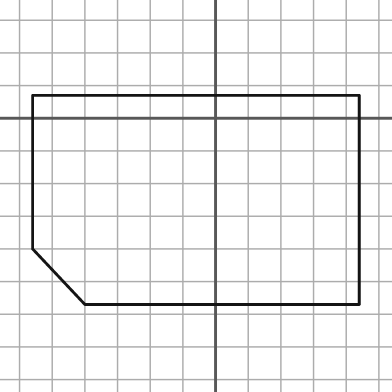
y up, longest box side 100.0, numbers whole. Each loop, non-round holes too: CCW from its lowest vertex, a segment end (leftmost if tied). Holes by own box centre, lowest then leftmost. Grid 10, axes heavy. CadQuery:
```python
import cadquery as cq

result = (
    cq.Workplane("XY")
    .moveTo(-40.0, -57.0)
    .lineTo(44.0, -57.0)
    .lineTo(44.0, 7.0)
    .lineTo(-56.0, 7.0)
    .lineTo(-56.0, -40.0)
    .close()
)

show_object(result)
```